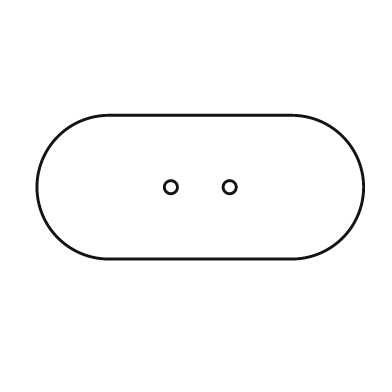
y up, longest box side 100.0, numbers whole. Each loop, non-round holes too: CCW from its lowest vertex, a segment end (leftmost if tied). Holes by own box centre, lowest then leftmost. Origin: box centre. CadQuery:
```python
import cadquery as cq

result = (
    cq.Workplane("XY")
    .moveTo(-28.0, -22.0)
    .lineTo(28.0, -22.0)
    .threePointArc((50.0, 0.0), (28.0, 22.0))
    .lineTo(-28.0, 22.0)
    .threePointArc((-50.0, 0.0), (-28.0, -22.0))
    .close()
    .moveTo(-9.0, 0.0)
    .circle(2.0)
    .moveTo(9.0, 0.0)
    .circle(2.0)
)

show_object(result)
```